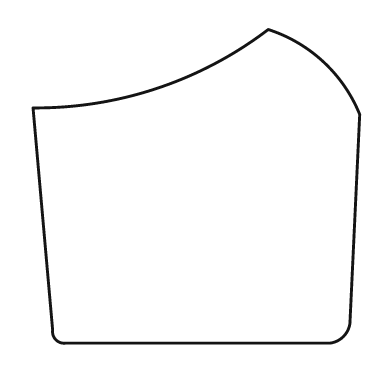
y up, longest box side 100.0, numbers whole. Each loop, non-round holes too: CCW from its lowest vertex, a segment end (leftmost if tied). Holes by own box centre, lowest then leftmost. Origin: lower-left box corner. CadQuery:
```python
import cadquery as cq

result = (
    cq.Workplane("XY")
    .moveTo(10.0, 0.0)
    .lineTo(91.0, 0.0)
    .threePointArc((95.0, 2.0), (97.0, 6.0))
    .lineTo(100.0, 70.0)
    .threePointArc((89.0, 86.0), (72.0, 96.0))
    .threePointArc((38.0, 78.0), (0.0, 72.0))
    .lineTo(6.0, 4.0)
    .threePointArc((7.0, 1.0), (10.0, 0.0))
    .close()
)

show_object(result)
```